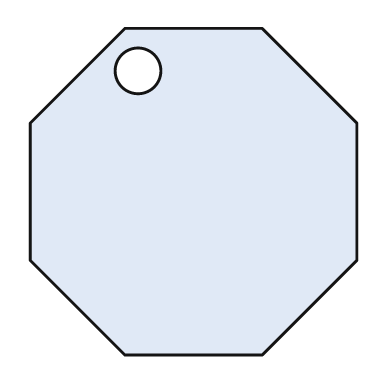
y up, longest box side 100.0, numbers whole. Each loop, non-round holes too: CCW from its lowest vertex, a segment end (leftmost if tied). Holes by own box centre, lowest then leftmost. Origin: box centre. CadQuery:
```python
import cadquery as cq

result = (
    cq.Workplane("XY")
    .moveTo(-21.0, -50.0)
    .lineTo(21.0, -50.0)
    .lineTo(50.0, -21.0)
    .lineTo(50.0, 21.0)
    .lineTo(21.0, 50.0)
    .lineTo(-21.0, 50.0)
    .lineTo(-50.0, 21.0)
    .lineTo(-50.0, -21.0)
    .close()
    .moveTo(-17.0, 37.0)
    .circle(7.0)
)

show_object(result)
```